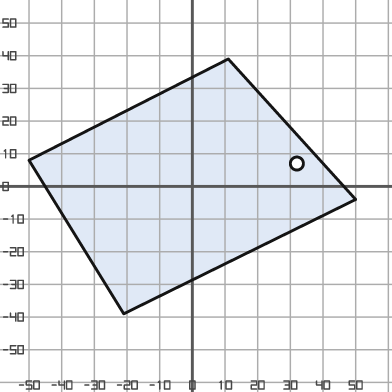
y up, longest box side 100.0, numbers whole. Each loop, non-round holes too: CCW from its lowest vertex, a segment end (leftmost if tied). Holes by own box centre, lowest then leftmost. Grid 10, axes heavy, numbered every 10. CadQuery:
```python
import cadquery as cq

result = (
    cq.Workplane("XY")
    .moveTo(-21.0, -39.0)
    .lineTo(50.0, -4.0)
    .lineTo(11.0, 39.0)
    .lineTo(-50.0, 8.0)
    .close()
    .moveTo(32.0, 7.0)
    .circle(2.0)
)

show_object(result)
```